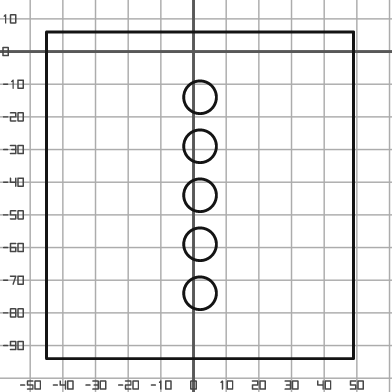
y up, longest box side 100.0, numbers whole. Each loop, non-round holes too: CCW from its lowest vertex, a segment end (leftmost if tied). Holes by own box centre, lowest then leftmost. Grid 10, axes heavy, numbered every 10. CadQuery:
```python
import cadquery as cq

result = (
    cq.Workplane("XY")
    .moveTo(-45.0, -94.0)
    .lineTo(49.0, -94.0)
    .lineTo(49.0, 6.0)
    .lineTo(-45.0, 6.0)
    .close()
    .moveTo(2.0, -74.0)
    .circle(5.0)
    .moveTo(2.0, -59.0)
    .circle(5.0)
    .moveTo(2.0, -44.0)
    .circle(5.0)
    .moveTo(2.0, -29.0)
    .circle(5.0)
    .moveTo(2.0, -14.0)
    .circle(5.0)
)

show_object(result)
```